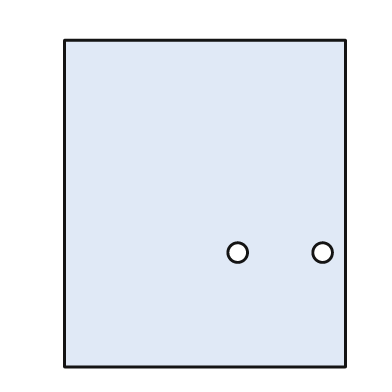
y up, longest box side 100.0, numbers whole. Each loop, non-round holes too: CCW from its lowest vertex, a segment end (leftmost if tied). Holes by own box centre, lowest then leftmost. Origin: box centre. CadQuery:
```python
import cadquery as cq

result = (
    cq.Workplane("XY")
    .moveTo(-43.0, -50.0)
    .lineTo(43.0, -50.0)
    .lineTo(43.0, 50.0)
    .lineTo(-43.0, 50.0)
    .close()
    .moveTo(10.0, -15.0)
    .circle(3.0)
    .moveTo(36.0, -15.0)
    .circle(3.0)
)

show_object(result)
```